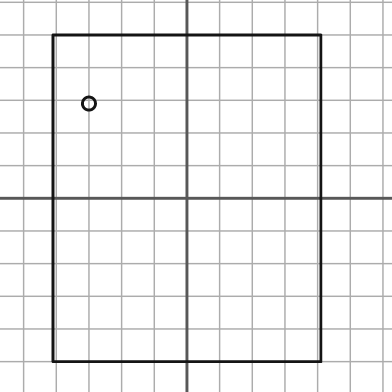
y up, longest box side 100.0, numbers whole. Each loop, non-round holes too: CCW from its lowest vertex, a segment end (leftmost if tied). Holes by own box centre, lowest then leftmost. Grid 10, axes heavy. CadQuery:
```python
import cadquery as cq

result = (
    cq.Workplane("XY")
    .moveTo(-41.0, -50.0)
    .lineTo(41.0, -50.0)
    .lineTo(41.0, 50.0)
    .lineTo(-41.0, 50.0)
    .close()
    .moveTo(-30.0, 29.0)
    .circle(2.0)
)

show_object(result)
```